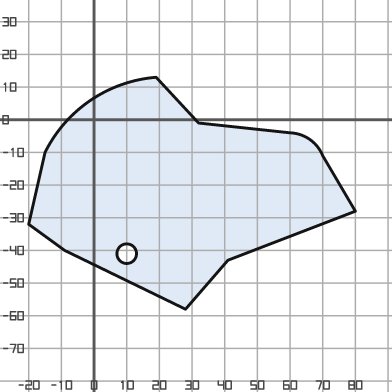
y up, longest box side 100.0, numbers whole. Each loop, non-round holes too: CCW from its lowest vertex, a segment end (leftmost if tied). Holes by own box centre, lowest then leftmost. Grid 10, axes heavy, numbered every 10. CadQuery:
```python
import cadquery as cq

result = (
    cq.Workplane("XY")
    .moveTo(28.0, -58.0)
    .lineTo(41.0, -43.0)
    .lineTo(80.0, -28.0)
    .lineTo(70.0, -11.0)
    .threePointArc((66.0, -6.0), (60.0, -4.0))
    .lineTo(32.0, -1.0)
    .lineTo(19.0, 13.0)
    .threePointArc((-1.0, 6.0), (-15.0, -10.0))
    .lineTo(-20.0, -32.0)
    .lineTo(-9.0, -40.0)
    .close()
    .moveTo(10.0, -41.0)
    .circle(3.0)
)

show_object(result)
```